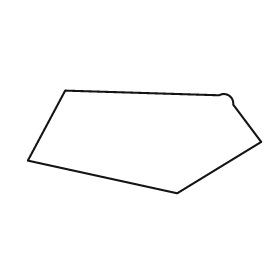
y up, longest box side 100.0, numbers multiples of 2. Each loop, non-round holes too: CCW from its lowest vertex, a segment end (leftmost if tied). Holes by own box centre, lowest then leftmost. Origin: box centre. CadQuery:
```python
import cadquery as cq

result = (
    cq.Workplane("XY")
    .moveTo(14.0, -22.0)
    .lineTo(50.0, 0.0)
    .lineTo(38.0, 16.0)
    .threePointArc((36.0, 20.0), (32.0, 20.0))
    .lineTo(-34.0, 22.0)
    .lineTo(-50.0, -8.0)
    .close()
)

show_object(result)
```